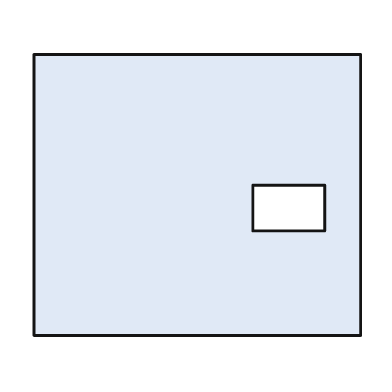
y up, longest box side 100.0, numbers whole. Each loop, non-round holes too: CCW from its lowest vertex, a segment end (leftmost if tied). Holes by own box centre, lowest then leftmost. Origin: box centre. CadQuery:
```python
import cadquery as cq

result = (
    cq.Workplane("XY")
    .moveTo(-50.0, -43.0)
    .lineTo(50.0, -43.0)
    .lineTo(50.0, 43.0)
    .lineTo(-50.0, 43.0)
    .close()
    .moveTo(17.0, -11.0)
    .lineTo(39.0, -11.0)
    .lineTo(39.0, 3.0)
    .lineTo(17.0, 3.0)
    .close()
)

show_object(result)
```